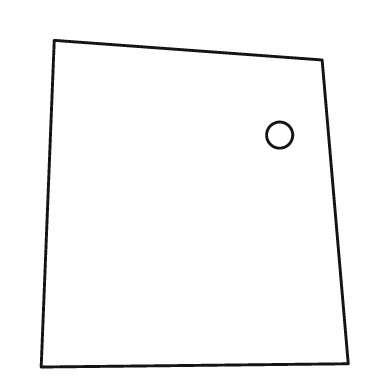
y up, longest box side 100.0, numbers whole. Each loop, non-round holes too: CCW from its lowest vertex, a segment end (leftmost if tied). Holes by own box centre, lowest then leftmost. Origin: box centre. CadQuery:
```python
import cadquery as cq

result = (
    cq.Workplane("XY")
    .moveTo(-47.0, -50.0)
    .lineTo(47.0, -49.0)
    .lineTo(39.0, 44.0)
    .lineTo(-43.0, 50.0)
    .close()
    .moveTo(26.0, 21.0)
    .circle(4.0)
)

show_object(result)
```